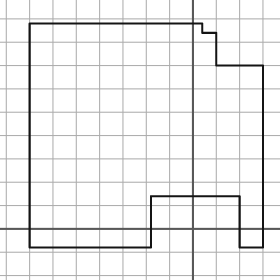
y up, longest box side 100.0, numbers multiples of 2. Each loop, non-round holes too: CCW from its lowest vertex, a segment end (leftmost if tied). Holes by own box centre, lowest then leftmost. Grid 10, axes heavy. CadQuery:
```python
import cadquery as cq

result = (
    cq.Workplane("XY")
    .moveTo(-70.0, -8.0)
    .lineTo(-18.0, -8.0)
    .lineTo(-18.0, 14.0)
    .lineTo(20.0, 14.0)
    .lineTo(20.0, -8.0)
    .lineTo(30.0, -8.0)
    .lineTo(30.0, 70.0)
    .lineTo(10.0, 70.0)
    .lineTo(10.0, 84.0)
    .lineTo(4.0, 84.0)
    .lineTo(4.0, 88.0)
    .lineTo(-70.0, 88.0)
    .close()
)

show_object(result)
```